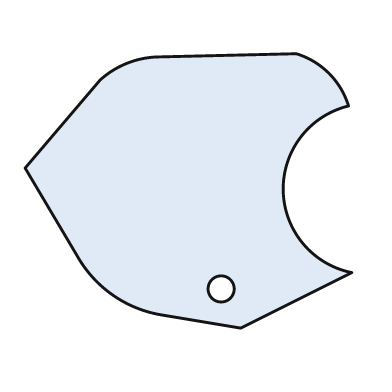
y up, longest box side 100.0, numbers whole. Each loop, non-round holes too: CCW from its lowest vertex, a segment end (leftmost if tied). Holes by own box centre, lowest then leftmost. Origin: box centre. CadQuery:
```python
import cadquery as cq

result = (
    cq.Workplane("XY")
    .moveTo(16.0, -42.0)
    .lineTo(50.0, -25.0)
    .threePointArc((29.0, 0.0), (49.0, 26.0))
    .threePointArc((43.0, 36.0), (33.0, 42.0))
    .lineTo(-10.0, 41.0)
    .threePointArc((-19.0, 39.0), (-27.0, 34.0))
    .lineTo(-50.0, 7.0)
    .lineTo(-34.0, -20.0)
    .threePointArc((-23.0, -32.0), (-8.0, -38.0))
    .close()
    .moveTo(10.0, -30.0)
    .circle(4.0)
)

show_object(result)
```